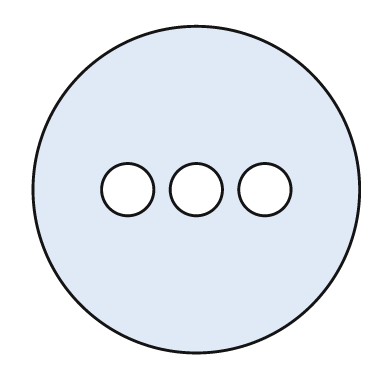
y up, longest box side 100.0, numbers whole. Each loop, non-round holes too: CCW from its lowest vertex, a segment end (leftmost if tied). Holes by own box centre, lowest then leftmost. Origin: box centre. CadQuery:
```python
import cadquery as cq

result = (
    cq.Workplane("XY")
    .moveTo(0.0, 0.0)
    .circle(50.0)
    .moveTo(-21.0, 0.0)
    .circle(8.0)
    .moveTo(0.0, 0.0)
    .circle(8.0)
    .moveTo(21.0, 0.0)
    .circle(8.0)
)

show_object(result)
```